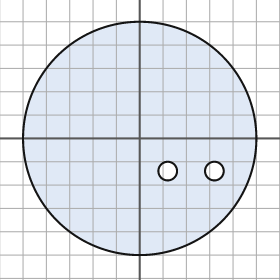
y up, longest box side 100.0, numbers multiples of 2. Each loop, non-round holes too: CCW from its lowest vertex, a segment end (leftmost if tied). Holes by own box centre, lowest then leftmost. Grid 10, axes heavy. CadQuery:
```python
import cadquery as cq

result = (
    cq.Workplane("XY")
    .moveTo(0.0, 0.0)
    .circle(50.0)
    .moveTo(12.0, -14.0)
    .circle(4.0)
    .moveTo(32.0, -14.0)
    .circle(4.0)
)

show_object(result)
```